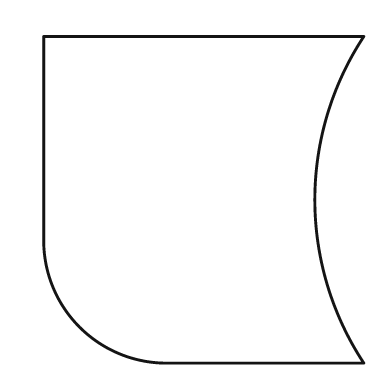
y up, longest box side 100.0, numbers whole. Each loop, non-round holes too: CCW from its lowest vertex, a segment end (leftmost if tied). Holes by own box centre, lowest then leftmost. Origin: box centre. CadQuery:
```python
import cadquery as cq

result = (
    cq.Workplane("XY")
    .moveTo(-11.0, -50.0)
    .lineTo(49.0, -50.0)
    .threePointArc((34.0, 0.0), (49.0, 50.0))
    .lineTo(-49.0, 50.0)
    .lineTo(-49.0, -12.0)
    .threePointArc((-38.0, -39.0), (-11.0, -50.0))
    .close()
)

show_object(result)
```